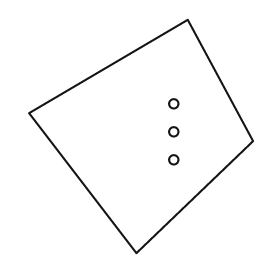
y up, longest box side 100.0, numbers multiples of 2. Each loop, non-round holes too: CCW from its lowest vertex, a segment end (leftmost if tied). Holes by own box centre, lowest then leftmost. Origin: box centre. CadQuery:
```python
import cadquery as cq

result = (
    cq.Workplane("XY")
    .moveTo(-2.0, -50.0)
    .lineTo(48.0, -2.0)
    .lineTo(20.0, 50.0)
    .lineTo(-48.0, 10.0)
    .close()
    .moveTo(14.0, -10.0)
    .circle(2.0)
    .moveTo(14.0, 2.0)
    .circle(2.0)
    .moveTo(14.0, 14.0)
    .circle(2.0)
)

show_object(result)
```